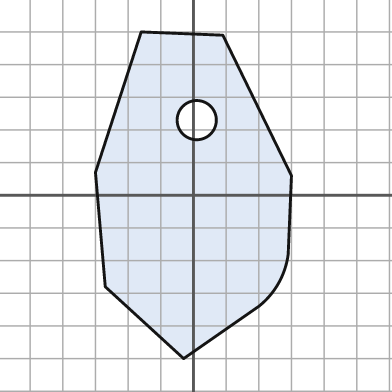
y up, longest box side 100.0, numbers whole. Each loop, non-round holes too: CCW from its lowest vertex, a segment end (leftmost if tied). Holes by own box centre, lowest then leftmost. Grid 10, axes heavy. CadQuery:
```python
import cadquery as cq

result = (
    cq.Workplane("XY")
    .moveTo(-3.0, -50.0)
    .lineTo(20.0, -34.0)
    .threePointArc((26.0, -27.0), (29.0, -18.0))
    .lineTo(30.0, 6.0)
    .lineTo(9.0, 49.0)
    .lineTo(-16.0, 50.0)
    .lineTo(-30.0, 7.0)
    .lineTo(-27.0, -28.0)
    .close()
    .moveTo(1.0, 23.0)
    .circle(6.0)
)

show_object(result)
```